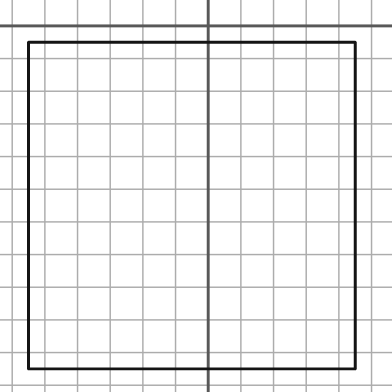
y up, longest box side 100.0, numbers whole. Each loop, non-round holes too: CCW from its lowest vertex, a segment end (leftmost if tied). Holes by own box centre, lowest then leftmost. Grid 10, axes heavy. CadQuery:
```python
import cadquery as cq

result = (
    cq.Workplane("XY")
    .moveTo(-55.0, -105.0)
    .lineTo(45.0, -105.0)
    .lineTo(45.0, -5.0)
    .lineTo(-55.0, -5.0)
    .close()
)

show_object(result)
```